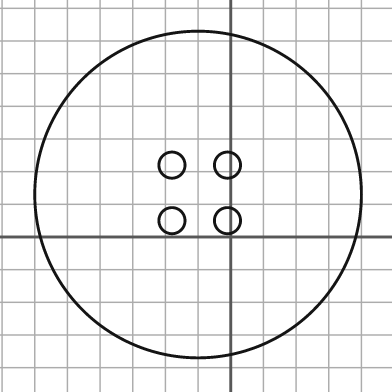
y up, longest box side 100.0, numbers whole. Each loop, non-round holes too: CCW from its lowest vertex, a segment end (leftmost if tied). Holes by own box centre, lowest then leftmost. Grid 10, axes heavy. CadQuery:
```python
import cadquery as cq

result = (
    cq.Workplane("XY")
    .moveTo(-10.0, 13.0)
    .circle(50.0)
    .moveTo(-18.0, 5.0)
    .circle(4.0)
    .moveTo(-1.0, 5.0)
    .circle(4.0)
    .moveTo(-18.0, 22.0)
    .circle(4.0)
    .moveTo(-1.0, 22.0)
    .circle(4.0)
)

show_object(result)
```